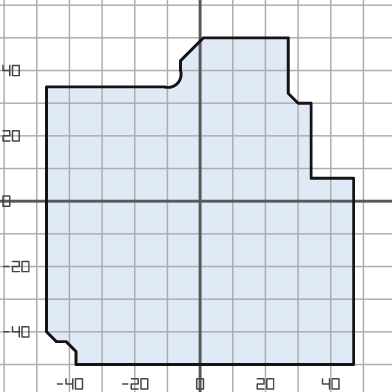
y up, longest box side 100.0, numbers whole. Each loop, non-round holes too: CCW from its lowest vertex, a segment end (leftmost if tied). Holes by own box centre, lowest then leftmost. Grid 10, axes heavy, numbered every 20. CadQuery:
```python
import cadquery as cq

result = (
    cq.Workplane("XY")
    .moveTo(-38.0, -50.0)
    .lineTo(47.0, -50.0)
    .lineTo(47.0, 7.0)
    .lineTo(34.0, 7.0)
    .lineTo(34.0, 30.0)
    .lineTo(30.0, 30.0)
    .lineTo(27.0, 33.0)
    .lineTo(27.0, 50.0)
    .lineTo(1.0, 50.0)
    .lineTo(-6.0, 43.0)
    .lineTo(-6.0, 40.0)
    .threePointArc((-7.0, 36.0), (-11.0, 35.0))
    .lineTo(-47.0, 35.0)
    .lineTo(-47.0, -40.0)
    .lineTo(-44.0, -43.0)
    .lineTo(-41.0, -43.0)
    .lineTo(-38.0, -46.0)
    .close()
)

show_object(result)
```